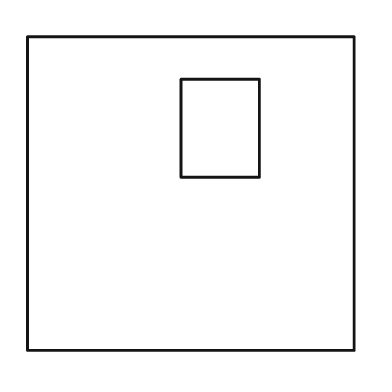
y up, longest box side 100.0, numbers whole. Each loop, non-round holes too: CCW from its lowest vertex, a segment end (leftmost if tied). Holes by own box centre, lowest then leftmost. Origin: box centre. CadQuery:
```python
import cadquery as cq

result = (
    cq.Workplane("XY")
    .moveTo(-50.0, -48.0)
    .lineTo(50.0, -48.0)
    .lineTo(50.0, 48.0)
    .lineTo(-50.0, 48.0)
    .close()
    .moveTo(-3.0, 5.0)
    .lineTo(21.0, 5.0)
    .lineTo(21.0, 35.0)
    .lineTo(-3.0, 35.0)
    .close()
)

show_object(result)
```